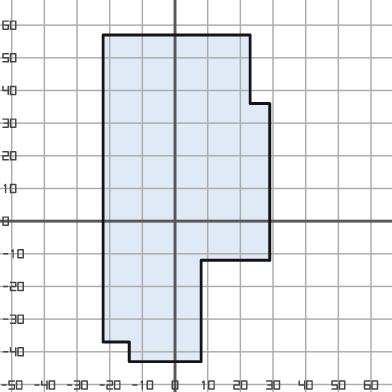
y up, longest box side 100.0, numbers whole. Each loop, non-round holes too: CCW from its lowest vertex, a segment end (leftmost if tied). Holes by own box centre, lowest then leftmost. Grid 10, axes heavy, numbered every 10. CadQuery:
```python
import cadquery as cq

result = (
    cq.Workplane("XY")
    .moveTo(-14.0, -43.0)
    .lineTo(8.0, -43.0)
    .lineTo(8.0, -12.0)
    .lineTo(29.0, -12.0)
    .lineTo(29.0, 36.0)
    .lineTo(23.0, 36.0)
    .lineTo(23.0, 57.0)
    .lineTo(-22.0, 57.0)
    .lineTo(-22.0, -37.0)
    .lineTo(-14.0, -37.0)
    .close()
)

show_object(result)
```